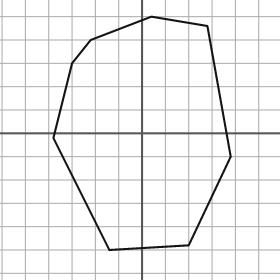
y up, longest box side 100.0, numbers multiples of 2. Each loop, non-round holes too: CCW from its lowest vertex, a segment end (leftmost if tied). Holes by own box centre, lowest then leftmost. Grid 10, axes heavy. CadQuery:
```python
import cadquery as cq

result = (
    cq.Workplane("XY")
    .moveTo(-14.0, -50.0)
    .lineTo(20.0, -48.0)
    .lineTo(38.0, -10.0)
    .lineTo(28.0, 46.0)
    .lineTo(4.0, 50.0)
    .lineTo(-22.0, 40.0)
    .lineTo(-30.0, 30.0)
    .lineTo(-38.0, -2.0)
    .close()
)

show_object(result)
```